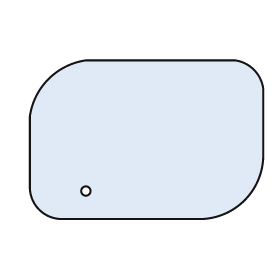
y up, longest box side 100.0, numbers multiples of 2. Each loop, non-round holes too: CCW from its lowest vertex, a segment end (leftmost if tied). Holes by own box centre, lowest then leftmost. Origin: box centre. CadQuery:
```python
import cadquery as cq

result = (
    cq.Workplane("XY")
    .moveTo(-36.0, -34.0)
    .lineTo(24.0, -34.0)
    .threePointArc((42.0, -26.0), (50.0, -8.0))
    .lineTo(50.0, 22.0)
    .threePointArc((46.0, 30.0), (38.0, 34.0))
    .lineTo(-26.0, 34.0)
    .threePointArc((-42.0, 26.0), (-50.0, 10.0))
    .lineTo(-50.0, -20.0)
    .threePointArc((-46.0, -30.0), (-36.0, -34.0))
    .close()
    .moveTo(-26.0, -22.0)
    .circle(2.0)
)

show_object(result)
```